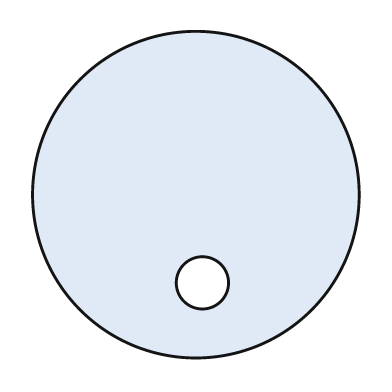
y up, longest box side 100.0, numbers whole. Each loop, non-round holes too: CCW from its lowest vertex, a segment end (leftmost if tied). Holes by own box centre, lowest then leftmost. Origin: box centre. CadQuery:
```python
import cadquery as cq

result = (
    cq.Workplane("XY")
    .moveTo(0.0, 0.0)
    .circle(50.0)
    .moveTo(2.0, -27.0)
    .circle(8.0)
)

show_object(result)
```